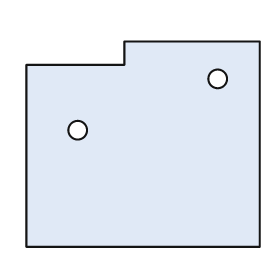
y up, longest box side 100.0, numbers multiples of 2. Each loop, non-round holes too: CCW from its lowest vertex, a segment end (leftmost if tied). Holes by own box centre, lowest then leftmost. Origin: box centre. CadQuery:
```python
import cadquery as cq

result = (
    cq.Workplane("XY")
    .moveTo(-50.0, -44.0)
    .lineTo(50.0, -44.0)
    .lineTo(50.0, 44.0)
    .lineTo(-8.0, 44.0)
    .lineTo(-8.0, 34.0)
    .lineTo(-50.0, 34.0)
    .close()
    .moveTo(-28.0, 6.0)
    .circle(4.0)
    .moveTo(32.0, 28.0)
    .circle(4.0)
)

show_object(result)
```